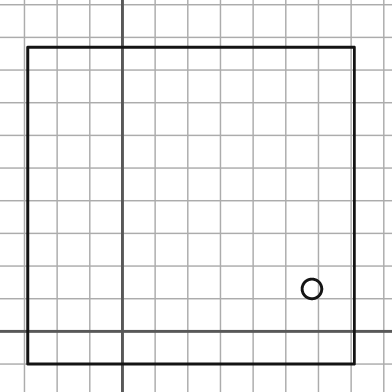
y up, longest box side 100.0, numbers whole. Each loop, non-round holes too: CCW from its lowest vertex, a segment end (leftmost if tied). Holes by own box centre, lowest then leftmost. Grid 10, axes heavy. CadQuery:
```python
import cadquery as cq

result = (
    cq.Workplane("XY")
    .moveTo(-29.0, -10.0)
    .lineTo(71.0, -10.0)
    .lineTo(71.0, 87.0)
    .lineTo(-29.0, 87.0)
    .close()
    .moveTo(58.0, 13.0)
    .circle(3.0)
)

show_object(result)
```